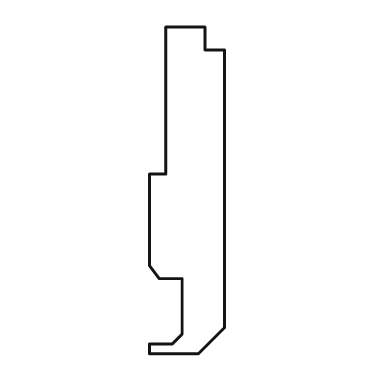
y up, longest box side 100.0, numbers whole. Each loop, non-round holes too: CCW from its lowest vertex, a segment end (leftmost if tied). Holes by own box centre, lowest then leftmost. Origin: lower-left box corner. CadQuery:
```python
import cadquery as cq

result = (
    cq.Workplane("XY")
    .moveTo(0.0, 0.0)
    .lineTo(15.0, 0.0)
    .lineTo(23.0, 8.0)
    .lineTo(23.0, 93.0)
    .lineTo(17.0, 93.0)
    .lineTo(17.0, 100.0)
    .lineTo(5.0, 100.0)
    .lineTo(5.0, 55.0)
    .lineTo(0.0, 55.0)
    .lineTo(0.0, 27.0)
    .lineTo(3.0, 23.0)
    .lineTo(10.0, 23.0)
    .lineTo(10.0, 6.0)
    .lineTo(7.0, 3.0)
    .lineTo(0.0, 3.0)
    .close()
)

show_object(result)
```